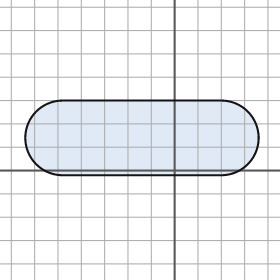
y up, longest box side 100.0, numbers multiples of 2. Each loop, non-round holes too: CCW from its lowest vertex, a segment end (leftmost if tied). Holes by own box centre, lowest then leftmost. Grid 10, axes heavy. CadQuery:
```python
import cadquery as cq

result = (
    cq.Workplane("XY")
    .moveTo(-48.0, -2.0)
    .lineTo(20.0, -2.0)
    .threePointArc((36.0, 14.0), (20.0, 30.0))
    .lineTo(-48.0, 30.0)
    .threePointArc((-64.0, 14.0), (-48.0, -2.0))
    .close()
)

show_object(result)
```